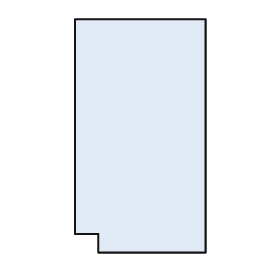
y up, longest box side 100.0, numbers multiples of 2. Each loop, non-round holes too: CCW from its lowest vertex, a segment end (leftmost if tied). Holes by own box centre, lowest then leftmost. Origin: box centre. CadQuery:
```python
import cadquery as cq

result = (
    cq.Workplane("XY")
    .moveTo(-18.0, -50.0)
    .lineTo(28.0, -50.0)
    .lineTo(28.0, 50.0)
    .lineTo(-28.0, 50.0)
    .lineTo(-28.0, -42.0)
    .lineTo(-18.0, -42.0)
    .close()
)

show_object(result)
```